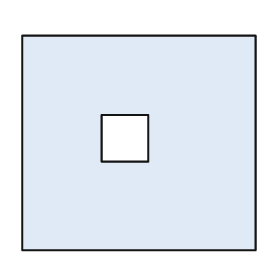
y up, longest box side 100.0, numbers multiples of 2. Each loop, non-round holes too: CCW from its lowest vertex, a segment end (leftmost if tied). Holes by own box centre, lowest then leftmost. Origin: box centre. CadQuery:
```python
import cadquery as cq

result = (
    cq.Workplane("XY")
    .moveTo(-50.0, -46.0)
    .lineTo(50.0, -46.0)
    .lineTo(50.0, 46.0)
    .lineTo(-50.0, 46.0)
    .close()
    .moveTo(-16.0, -8.0)
    .lineTo(4.0, -8.0)
    .lineTo(4.0, 12.0)
    .lineTo(-16.0, 12.0)
    .close()
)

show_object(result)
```